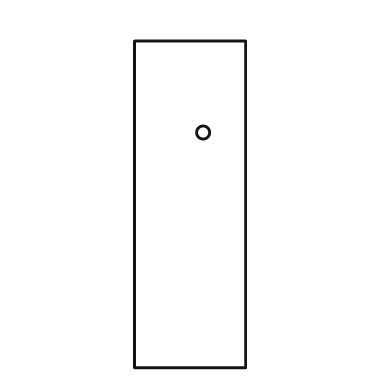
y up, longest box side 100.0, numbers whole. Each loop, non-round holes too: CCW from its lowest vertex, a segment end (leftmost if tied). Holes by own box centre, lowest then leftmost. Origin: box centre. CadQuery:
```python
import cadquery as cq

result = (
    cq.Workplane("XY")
    .moveTo(-17.0, -50.0)
    .lineTo(17.0, -50.0)
    .lineTo(17.0, 50.0)
    .lineTo(-17.0, 50.0)
    .close()
    .moveTo(4.0, 22.0)
    .circle(2.0)
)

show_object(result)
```